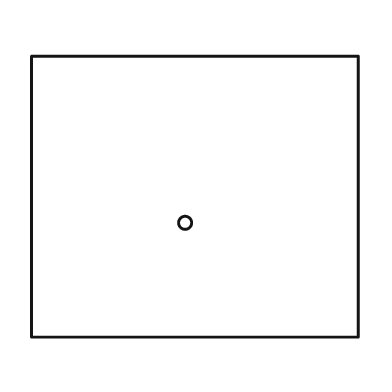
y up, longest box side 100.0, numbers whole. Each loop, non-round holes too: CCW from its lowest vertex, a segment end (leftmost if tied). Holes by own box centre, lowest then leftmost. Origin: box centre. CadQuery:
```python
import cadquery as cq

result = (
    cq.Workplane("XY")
    .moveTo(-50.0, -43.0)
    .lineTo(50.0, -43.0)
    .lineTo(50.0, 43.0)
    .lineTo(-50.0, 43.0)
    .close()
    .moveTo(-3.0, -8.0)
    .circle(2.0)
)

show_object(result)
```